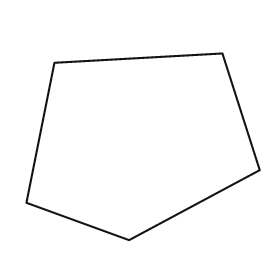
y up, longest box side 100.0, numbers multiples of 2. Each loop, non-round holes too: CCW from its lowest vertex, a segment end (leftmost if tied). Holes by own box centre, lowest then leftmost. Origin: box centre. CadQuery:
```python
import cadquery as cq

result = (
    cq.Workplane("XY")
    .moveTo(-6.0, -40.0)
    .lineTo(50.0, -10.0)
    .lineTo(34.0, 40.0)
    .lineTo(-38.0, 36.0)
    .lineTo(-50.0, -24.0)
    .close()
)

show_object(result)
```